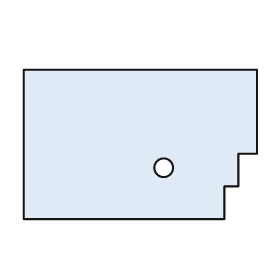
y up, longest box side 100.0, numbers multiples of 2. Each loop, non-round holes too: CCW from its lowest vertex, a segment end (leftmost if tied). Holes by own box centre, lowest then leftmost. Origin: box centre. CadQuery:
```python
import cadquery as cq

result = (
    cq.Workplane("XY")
    .moveTo(-50.0, -32.0)
    .lineTo(36.0, -32.0)
    .lineTo(36.0, -18.0)
    .lineTo(42.0, -18.0)
    .lineTo(42.0, -4.0)
    .lineTo(50.0, -4.0)
    .lineTo(50.0, 32.0)
    .lineTo(-50.0, 32.0)
    .close()
    .moveTo(10.0, -10.0)
    .circle(4.0)
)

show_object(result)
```